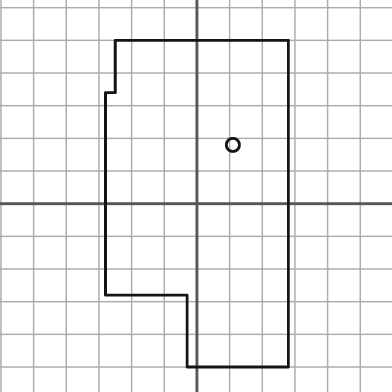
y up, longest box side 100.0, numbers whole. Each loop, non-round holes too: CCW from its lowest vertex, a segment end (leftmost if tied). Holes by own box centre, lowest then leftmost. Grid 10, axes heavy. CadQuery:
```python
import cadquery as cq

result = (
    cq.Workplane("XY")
    .moveTo(-3.0, -50.0)
    .lineTo(28.0, -50.0)
    .lineTo(28.0, 50.0)
    .lineTo(-25.0, 50.0)
    .lineTo(-25.0, 34.0)
    .lineTo(-28.0, 34.0)
    .lineTo(-28.0, -28.0)
    .lineTo(-3.0, -28.0)
    .close()
    .moveTo(11.0, 18.0)
    .circle(2.0)
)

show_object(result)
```